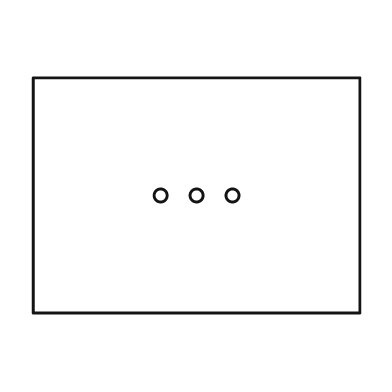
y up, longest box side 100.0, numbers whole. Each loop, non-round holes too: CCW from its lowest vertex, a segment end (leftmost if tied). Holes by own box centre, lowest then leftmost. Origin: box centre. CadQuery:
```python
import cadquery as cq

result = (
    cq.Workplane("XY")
    .moveTo(-50.0, -36.0)
    .lineTo(50.0, -36.0)
    .lineTo(50.0, 36.0)
    .lineTo(-50.0, 36.0)
    .close()
    .moveTo(-11.0, 0.0)
    .circle(2.0)
    .moveTo(0.0, 0.0)
    .circle(2.0)
    .moveTo(11.0, 0.0)
    .circle(2.0)
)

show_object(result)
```